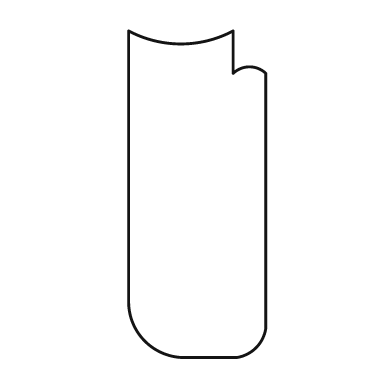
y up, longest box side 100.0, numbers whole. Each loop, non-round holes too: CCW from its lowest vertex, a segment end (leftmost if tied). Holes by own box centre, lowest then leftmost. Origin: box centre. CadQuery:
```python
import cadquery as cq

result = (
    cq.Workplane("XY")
    .moveTo(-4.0, -50.0)
    .lineTo(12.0, -50.0)
    .threePointArc((18.0, -47.0), (21.0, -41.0))
    .lineTo(21.0, 37.0)
    .threePointArc((16.0, 39.0), (11.0, 37.0))
    .lineTo(11.0, 50.0)
    .threePointArc((-5.0, 46.0), (-21.0, 50.0))
    .lineTo(-21.0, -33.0)
    .threePointArc((-16.0, -45.0), (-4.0, -50.0))
    .close()
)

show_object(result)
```